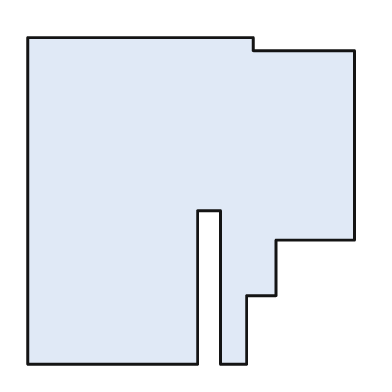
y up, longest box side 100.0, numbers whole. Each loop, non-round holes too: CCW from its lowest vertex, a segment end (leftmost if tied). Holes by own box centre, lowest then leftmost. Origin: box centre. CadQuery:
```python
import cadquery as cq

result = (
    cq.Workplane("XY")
    .moveTo(-50.0, -50.0)
    .lineTo(2.0, -50.0)
    .lineTo(2.0, -3.0)
    .lineTo(9.0, -3.0)
    .lineTo(9.0, -50.0)
    .lineTo(17.0, -50.0)
    .lineTo(17.0, -29.0)
    .lineTo(26.0, -29.0)
    .lineTo(26.0, -12.0)
    .lineTo(50.0, -12.0)
    .lineTo(50.0, 46.0)
    .lineTo(19.0, 46.0)
    .lineTo(19.0, 50.0)
    .lineTo(-50.0, 50.0)
    .close()
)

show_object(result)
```